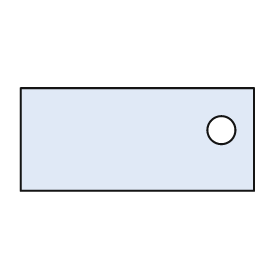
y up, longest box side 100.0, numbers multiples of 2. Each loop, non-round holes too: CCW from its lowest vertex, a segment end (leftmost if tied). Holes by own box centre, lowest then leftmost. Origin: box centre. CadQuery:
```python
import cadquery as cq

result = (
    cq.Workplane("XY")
    .moveTo(-50.0, -22.0)
    .lineTo(50.0, -22.0)
    .lineTo(50.0, 22.0)
    .lineTo(-50.0, 22.0)
    .close()
    .moveTo(36.0, 4.0)
    .circle(6.0)
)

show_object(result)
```